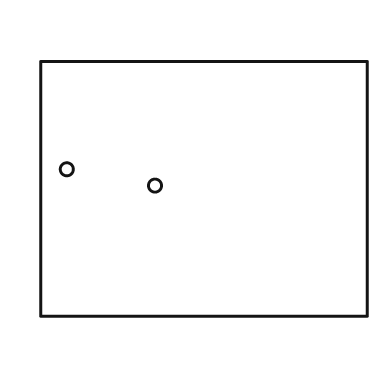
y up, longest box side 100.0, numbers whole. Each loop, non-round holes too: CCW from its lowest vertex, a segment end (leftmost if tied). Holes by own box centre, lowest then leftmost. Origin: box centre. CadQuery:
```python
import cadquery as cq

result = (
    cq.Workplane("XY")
    .moveTo(-50.0, -39.0)
    .lineTo(50.0, -39.0)
    .lineTo(50.0, 39.0)
    .lineTo(-50.0, 39.0)
    .close()
    .moveTo(-15.0, 1.0)
    .circle(2.0)
    .moveTo(-42.0, 6.0)
    .circle(2.0)
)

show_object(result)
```